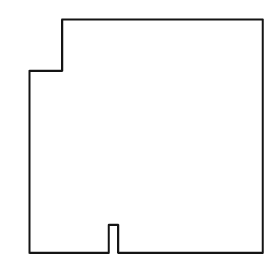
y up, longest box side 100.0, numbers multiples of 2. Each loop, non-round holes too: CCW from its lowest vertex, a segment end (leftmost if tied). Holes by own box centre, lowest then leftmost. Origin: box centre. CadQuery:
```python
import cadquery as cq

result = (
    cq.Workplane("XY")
    .moveTo(-50.0, -50.0)
    .lineTo(-16.0, -50.0)
    .lineTo(-16.0, -38.0)
    .lineTo(-12.0, -38.0)
    .lineTo(-12.0, -50.0)
    .lineTo(50.0, -50.0)
    .lineTo(50.0, 50.0)
    .lineTo(-36.0, 50.0)
    .lineTo(-36.0, 28.0)
    .lineTo(-50.0, 28.0)
    .close()
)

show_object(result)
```